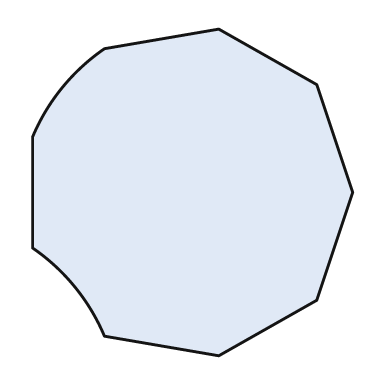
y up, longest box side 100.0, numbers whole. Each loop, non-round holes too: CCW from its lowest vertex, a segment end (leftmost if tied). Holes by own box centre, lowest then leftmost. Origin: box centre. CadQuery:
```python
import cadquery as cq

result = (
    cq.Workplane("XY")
    .moveTo(8.0, -50.0)
    .lineTo(38.0, -33.0)
    .lineTo(49.0, 0.0)
    .lineTo(38.0, 33.0)
    .lineTo(8.0, 50.0)
    .lineTo(-27.0, 44.0)
    .threePointArc((-40.0, 32.0), (-49.0, 17.0))
    .lineTo(-49.0, -17.0)
    .threePointArc((-36.0, -29.0), (-27.0, -44.0))
    .close()
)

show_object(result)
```